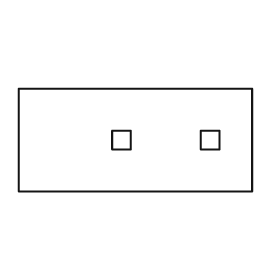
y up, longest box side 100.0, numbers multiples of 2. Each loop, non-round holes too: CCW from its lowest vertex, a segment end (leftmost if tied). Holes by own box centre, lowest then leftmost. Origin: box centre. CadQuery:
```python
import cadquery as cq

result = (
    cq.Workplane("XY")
    .moveTo(-50.0, -22.0)
    .lineTo(50.0, -22.0)
    .lineTo(50.0, 22.0)
    .lineTo(-50.0, 22.0)
    .close()
    .moveTo(-10.0, -4.0)
    .lineTo(-2.0, -4.0)
    .lineTo(-2.0, 4.0)
    .lineTo(-10.0, 4.0)
    .close()
    .moveTo(28.0, -4.0)
    .lineTo(36.0, -4.0)
    .lineTo(36.0, 4.0)
    .lineTo(28.0, 4.0)
    .close()
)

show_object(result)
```